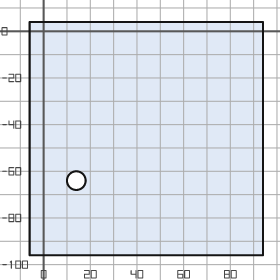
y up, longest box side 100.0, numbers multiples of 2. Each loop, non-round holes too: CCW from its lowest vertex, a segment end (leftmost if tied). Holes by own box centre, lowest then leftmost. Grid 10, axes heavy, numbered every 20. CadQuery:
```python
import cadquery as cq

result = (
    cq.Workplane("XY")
    .moveTo(-6.0, -96.0)
    .lineTo(94.0, -96.0)
    .lineTo(94.0, 4.0)
    .lineTo(-6.0, 4.0)
    .close()
    .moveTo(14.0, -64.0)
    .circle(4.0)
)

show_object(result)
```